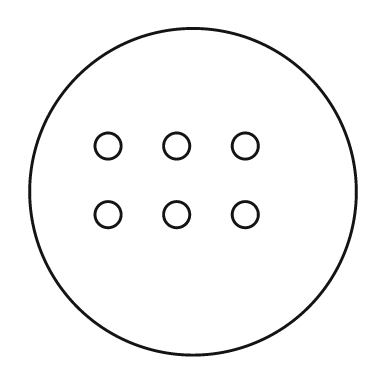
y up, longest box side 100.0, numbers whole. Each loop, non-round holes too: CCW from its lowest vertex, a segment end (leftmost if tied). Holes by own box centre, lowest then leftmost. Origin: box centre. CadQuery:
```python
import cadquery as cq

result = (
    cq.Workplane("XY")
    .moveTo(0.0, 0.0)
    .circle(50.0)
    .moveTo(-26.0, -7.0)
    .circle(4.0)
    .moveTo(-5.0, -7.0)
    .circle(4.0)
    .moveTo(16.0, -7.0)
    .circle(4.0)
    .moveTo(-26.0, 14.0)
    .circle(4.0)
    .moveTo(-5.0, 14.0)
    .circle(4.0)
    .moveTo(16.0, 14.0)
    .circle(4.0)
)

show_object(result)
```